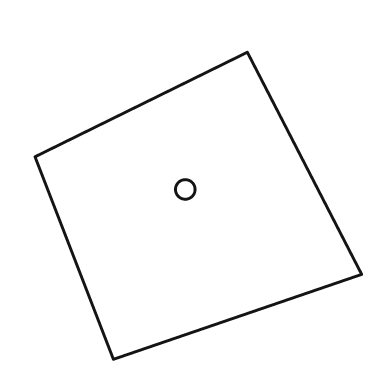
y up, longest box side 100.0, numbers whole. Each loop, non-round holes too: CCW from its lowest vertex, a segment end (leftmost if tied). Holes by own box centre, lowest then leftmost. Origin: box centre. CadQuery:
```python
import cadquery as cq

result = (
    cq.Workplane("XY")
    .moveTo(-26.0, -47.0)
    .lineTo(50.0, -21.0)
    .lineTo(15.0, 47.0)
    .lineTo(-50.0, 15.0)
    .close()
    .moveTo(-4.0, 5.0)
    .circle(3.0)
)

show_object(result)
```